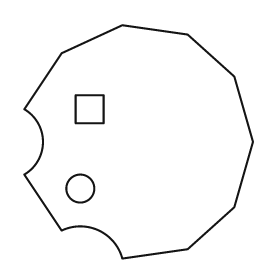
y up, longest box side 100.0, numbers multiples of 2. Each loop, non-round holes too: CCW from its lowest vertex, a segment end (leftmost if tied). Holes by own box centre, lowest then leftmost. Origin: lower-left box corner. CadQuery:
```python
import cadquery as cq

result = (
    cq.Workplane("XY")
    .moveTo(42.0, 0.0)
    .lineTo(70.0, 4.0)
    .lineTo(90.0, 22.0)
    .lineTo(98.0, 50.0)
    .lineTo(90.0, 78.0)
    .lineTo(70.0, 96.0)
    .lineTo(42.0, 100.0)
    .lineTo(16.0, 88.0)
    .lineTo(0.0, 64.0)
    .threePointArc((8.0, 50.0), (0.0, 36.0))
    .lineTo(16.0, 12.0)
    .threePointArc((32.0, 12.0), (42.0, 0.0))
    .close()
    .moveTo(24.0, 30.0)
    .circle(6.0)
    .moveTo(22.0, 58.0)
    .lineTo(34.0, 58.0)
    .lineTo(34.0, 70.0)
    .lineTo(22.0, 70.0)
    .close()
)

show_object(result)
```